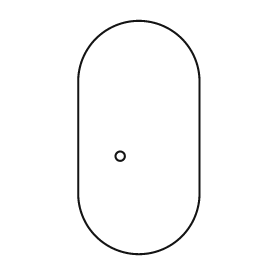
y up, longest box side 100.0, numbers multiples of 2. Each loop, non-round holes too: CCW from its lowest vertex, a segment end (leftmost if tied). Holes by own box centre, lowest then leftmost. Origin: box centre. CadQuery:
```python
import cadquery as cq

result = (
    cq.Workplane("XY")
    .moveTo(-26.0, -24.0)
    .threePointArc((0.0, -50.0), (26.0, -24.0))
    .lineTo(26.0, 24.0)
    .threePointArc((0.0, 50.0), (-26.0, 24.0))
    .close()
    .moveTo(-8.0, -8.0)
    .circle(2.0)
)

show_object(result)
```